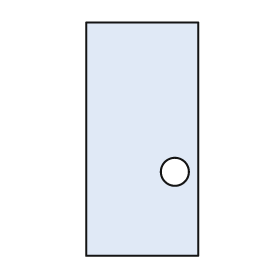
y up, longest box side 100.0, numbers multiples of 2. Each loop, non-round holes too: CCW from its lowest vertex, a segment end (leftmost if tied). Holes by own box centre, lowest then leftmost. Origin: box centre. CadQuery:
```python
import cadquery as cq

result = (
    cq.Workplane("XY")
    .moveTo(-24.0, -50.0)
    .lineTo(24.0, -50.0)
    .lineTo(24.0, 50.0)
    .lineTo(-24.0, 50.0)
    .close()
    .moveTo(14.0, -14.0)
    .circle(6.0)
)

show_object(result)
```